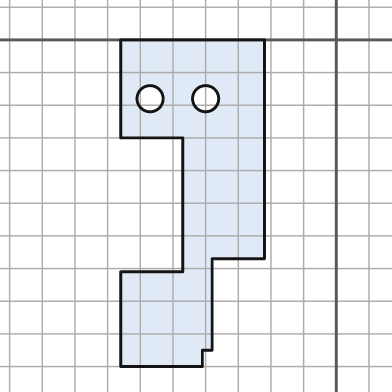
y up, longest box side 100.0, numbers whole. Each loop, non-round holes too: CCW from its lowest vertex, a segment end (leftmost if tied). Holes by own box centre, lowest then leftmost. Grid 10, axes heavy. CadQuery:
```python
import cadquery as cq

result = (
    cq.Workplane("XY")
    .moveTo(-66.0, -100.0)
    .lineTo(-41.0, -100.0)
    .lineTo(-41.0, -95.0)
    .lineTo(-38.0, -95.0)
    .lineTo(-38.0, -67.0)
    .lineTo(-22.0, -67.0)
    .lineTo(-22.0, 0.0)
    .lineTo(-66.0, 0.0)
    .lineTo(-66.0, -30.0)
    .lineTo(-47.0, -30.0)
    .lineTo(-47.0, -71.0)
    .lineTo(-66.0, -71.0)
    .close()
    .moveTo(-57.0, -18.0)
    .circle(4.0)
    .moveTo(-40.0, -18.0)
    .circle(4.0)
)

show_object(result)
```